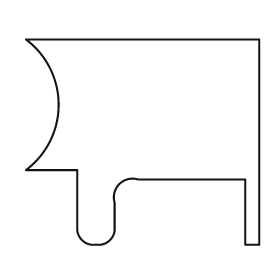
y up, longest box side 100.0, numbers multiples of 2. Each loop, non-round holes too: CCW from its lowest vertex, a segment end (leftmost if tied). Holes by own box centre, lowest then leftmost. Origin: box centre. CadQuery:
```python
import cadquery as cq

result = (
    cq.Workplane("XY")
    .moveTo(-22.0, -44.0)
    .lineTo(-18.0, -44.0)
    .threePointArc((-14.0, -42.0), (-12.0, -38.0))
    .lineTo(-12.0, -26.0)
    .threePointArc((-10.0, -18.0), (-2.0, -16.0))
    .lineTo(44.0, -16.0)
    .lineTo(44.0, -44.0)
    .lineTo(50.0, -44.0)
    .lineTo(50.0, 44.0)
    .lineTo(-50.0, 44.0)
    .threePointArc((-36.0, 16.0), (-50.0, -12.0))
    .lineTo(-28.0, -12.0)
    .lineTo(-28.0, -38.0)
    .threePointArc((-26.0, -42.0), (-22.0, -44.0))
    .close()
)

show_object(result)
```